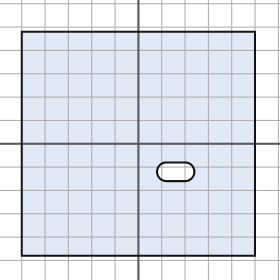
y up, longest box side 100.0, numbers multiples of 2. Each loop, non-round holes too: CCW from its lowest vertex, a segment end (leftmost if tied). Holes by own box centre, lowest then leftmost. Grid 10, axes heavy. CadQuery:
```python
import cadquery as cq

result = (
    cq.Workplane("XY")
    .moveTo(-50.0, -48.0)
    .lineTo(50.0, -48.0)
    .lineTo(50.0, 48.0)
    .lineTo(-50.0, 48.0)
    .close()
    .moveTo(12.0, -16.0)
    .lineTo(20.0, -16.0)
    .threePointArc((24.0, -12.0), (20.0, -8.0))
    .lineTo(12.0, -8.0)
    .threePointArc((8.0, -12.0), (12.0, -16.0))
    .close()
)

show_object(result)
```